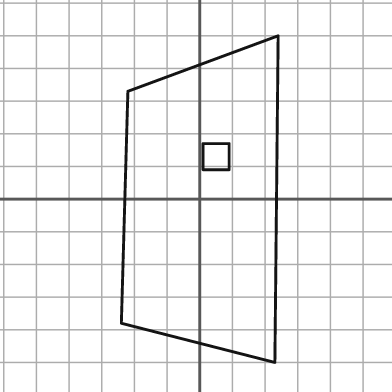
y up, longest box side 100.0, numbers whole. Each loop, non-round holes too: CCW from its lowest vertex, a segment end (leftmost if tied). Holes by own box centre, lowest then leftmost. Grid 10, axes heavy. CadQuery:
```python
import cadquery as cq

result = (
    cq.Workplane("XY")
    .moveTo(23.0, -50.0)
    .lineTo(24.0, 50.0)
    .lineTo(-22.0, 33.0)
    .lineTo(-24.0, -38.0)
    .close()
    .moveTo(1.0, 9.0)
    .lineTo(9.0, 9.0)
    .lineTo(9.0, 17.0)
    .lineTo(1.0, 17.0)
    .close()
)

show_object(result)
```